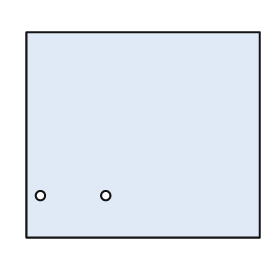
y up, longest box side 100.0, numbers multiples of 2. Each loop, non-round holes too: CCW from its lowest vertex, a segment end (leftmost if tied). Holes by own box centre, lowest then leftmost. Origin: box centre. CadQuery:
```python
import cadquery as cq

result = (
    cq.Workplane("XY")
    .moveTo(-50.0, -44.0)
    .lineTo(50.0, -44.0)
    .lineTo(50.0, 44.0)
    .lineTo(-50.0, 44.0)
    .close()
    .moveTo(-44.0, -26.0)
    .circle(2.0)
    .moveTo(-16.0, -26.0)
    .circle(2.0)
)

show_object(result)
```